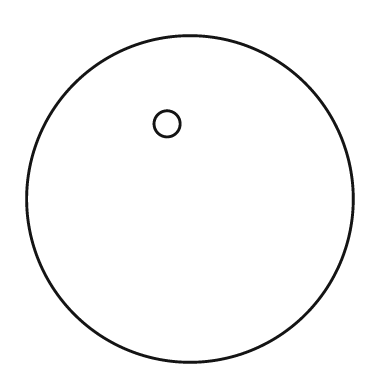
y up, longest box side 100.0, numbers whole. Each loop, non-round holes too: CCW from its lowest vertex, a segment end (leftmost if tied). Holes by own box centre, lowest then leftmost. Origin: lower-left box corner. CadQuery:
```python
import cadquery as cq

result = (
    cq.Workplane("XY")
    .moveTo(50.0, 50.0)
    .circle(50.0)
    .moveTo(43.0, 73.0)
    .circle(4.0)
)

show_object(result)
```